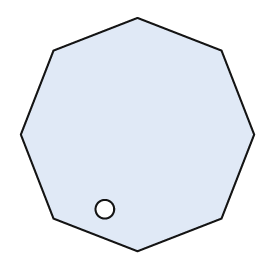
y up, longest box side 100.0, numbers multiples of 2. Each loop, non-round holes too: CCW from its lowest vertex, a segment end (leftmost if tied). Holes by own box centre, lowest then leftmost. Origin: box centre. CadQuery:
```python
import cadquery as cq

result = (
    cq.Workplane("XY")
    .moveTo(0.0, -50.0)
    .lineTo(36.0, -36.0)
    .lineTo(50.0, 0.0)
    .lineTo(36.0, 36.0)
    .lineTo(0.0, 50.0)
    .lineTo(-36.0, 36.0)
    .lineTo(-50.0, 0.0)
    .lineTo(-36.0, -36.0)
    .close()
    .moveTo(-14.0, -32.0)
    .circle(4.0)
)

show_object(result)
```